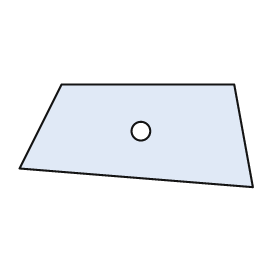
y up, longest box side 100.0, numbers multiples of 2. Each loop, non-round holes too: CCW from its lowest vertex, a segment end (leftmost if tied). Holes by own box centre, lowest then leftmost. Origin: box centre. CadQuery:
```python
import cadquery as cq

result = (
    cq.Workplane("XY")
    .moveTo(50.0, -22.0)
    .lineTo(42.0, 22.0)
    .lineTo(-32.0, 22.0)
    .lineTo(-50.0, -14.0)
    .close()
    .moveTo(2.0, 2.0)
    .circle(4.0)
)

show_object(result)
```